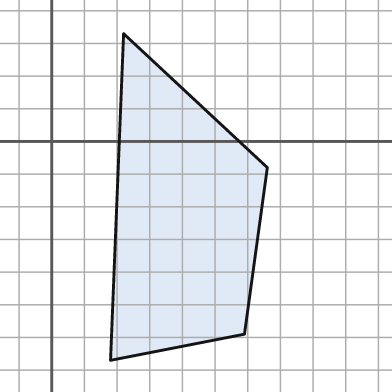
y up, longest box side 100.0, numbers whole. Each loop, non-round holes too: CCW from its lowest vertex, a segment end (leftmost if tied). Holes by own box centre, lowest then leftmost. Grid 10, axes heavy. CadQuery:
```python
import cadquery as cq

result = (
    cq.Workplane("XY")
    .moveTo(18.0, -67.0)
    .lineTo(59.0, -59.0)
    .lineTo(66.0, -8.0)
    .lineTo(22.0, 33.0)
    .close()
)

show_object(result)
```